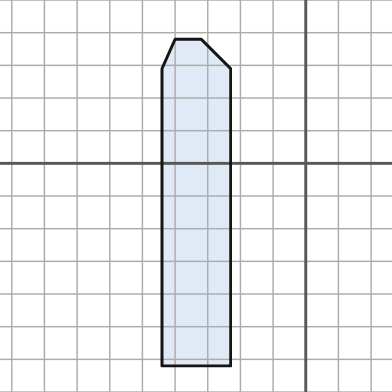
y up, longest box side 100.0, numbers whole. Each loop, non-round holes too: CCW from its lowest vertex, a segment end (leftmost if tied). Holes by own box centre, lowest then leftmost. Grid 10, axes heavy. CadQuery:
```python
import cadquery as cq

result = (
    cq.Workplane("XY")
    .moveTo(-44.0, -62.0)
    .lineTo(-23.0, -62.0)
    .lineTo(-23.0, 29.0)
    .lineTo(-32.0, 38.0)
    .lineTo(-40.0, 38.0)
    .lineTo(-44.0, 29.0)
    .close()
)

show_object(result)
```